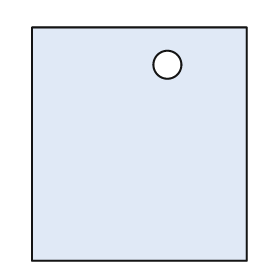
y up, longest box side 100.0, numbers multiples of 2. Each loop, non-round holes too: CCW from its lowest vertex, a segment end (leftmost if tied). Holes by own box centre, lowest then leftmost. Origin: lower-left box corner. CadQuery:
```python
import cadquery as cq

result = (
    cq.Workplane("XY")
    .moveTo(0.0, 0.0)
    .lineTo(92.0, 0.0)
    .lineTo(92.0, 100.0)
    .lineTo(0.0, 100.0)
    .close()
    .moveTo(58.0, 84.0)
    .circle(6.0)
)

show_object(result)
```